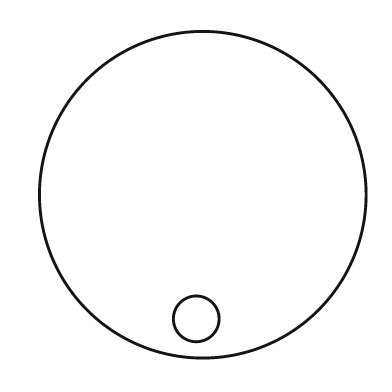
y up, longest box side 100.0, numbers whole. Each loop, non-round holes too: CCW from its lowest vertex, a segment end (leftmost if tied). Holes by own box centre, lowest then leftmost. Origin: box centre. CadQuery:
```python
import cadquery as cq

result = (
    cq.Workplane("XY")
    .moveTo(0.0, 0.0)
    .circle(50.0)
    .moveTo(-2.0, -38.0)
    .circle(7.0)
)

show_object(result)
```